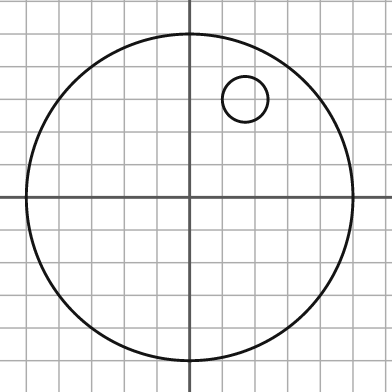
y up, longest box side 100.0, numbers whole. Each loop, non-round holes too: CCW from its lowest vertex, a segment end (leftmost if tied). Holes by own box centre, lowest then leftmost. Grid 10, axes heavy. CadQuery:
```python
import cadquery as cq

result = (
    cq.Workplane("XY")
    .moveTo(0.0, 0.0)
    .circle(50.0)
    .moveTo(17.0, 30.0)
    .circle(7.0)
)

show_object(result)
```